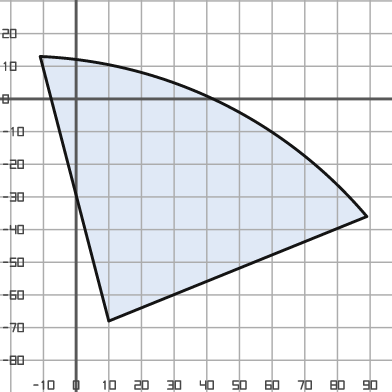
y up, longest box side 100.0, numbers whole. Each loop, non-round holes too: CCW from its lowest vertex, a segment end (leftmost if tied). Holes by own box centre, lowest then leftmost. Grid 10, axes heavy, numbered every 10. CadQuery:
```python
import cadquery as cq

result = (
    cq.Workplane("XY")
    .moveTo(10.0, -68.0)
    .lineTo(89.0, -36.0)
    .threePointArc((44.0, -1.0), (-11.0, 13.0))
    .close()
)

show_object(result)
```